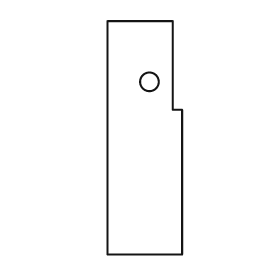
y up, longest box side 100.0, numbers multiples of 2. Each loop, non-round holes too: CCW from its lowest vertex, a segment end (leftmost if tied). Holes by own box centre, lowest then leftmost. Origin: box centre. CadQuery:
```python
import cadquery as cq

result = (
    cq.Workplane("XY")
    .moveTo(-16.0, -50.0)
    .lineTo(16.0, -50.0)
    .lineTo(16.0, 12.0)
    .lineTo(12.0, 12.0)
    .lineTo(12.0, 50.0)
    .lineTo(-16.0, 50.0)
    .close()
    .moveTo(2.0, 24.0)
    .circle(4.0)
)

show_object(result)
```